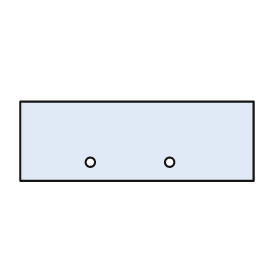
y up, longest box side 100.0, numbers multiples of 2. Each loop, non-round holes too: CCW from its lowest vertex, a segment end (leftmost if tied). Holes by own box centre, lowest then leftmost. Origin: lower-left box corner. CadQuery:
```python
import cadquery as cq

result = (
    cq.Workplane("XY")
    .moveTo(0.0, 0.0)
    .lineTo(100.0, 0.0)
    .lineTo(100.0, 34.0)
    .lineTo(0.0, 34.0)
    .close()
    .moveTo(30.0, 8.0)
    .circle(2.0)
    .moveTo(64.0, 8.0)
    .circle(2.0)
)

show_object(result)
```